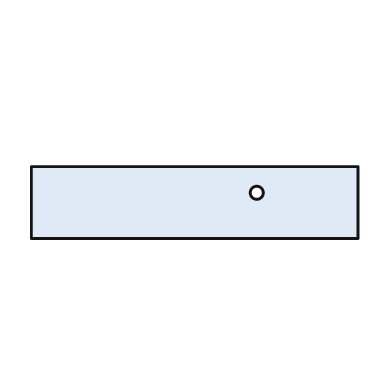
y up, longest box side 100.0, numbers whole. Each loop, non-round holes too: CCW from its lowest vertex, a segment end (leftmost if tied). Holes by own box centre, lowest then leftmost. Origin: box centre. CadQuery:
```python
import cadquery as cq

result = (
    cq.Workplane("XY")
    .moveTo(-50.0, -11.0)
    .lineTo(50.0, -11.0)
    .lineTo(50.0, 11.0)
    .lineTo(-50.0, 11.0)
    .close()
    .moveTo(19.0, 3.0)
    .circle(2.0)
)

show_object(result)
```